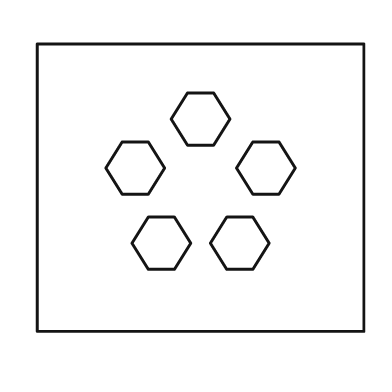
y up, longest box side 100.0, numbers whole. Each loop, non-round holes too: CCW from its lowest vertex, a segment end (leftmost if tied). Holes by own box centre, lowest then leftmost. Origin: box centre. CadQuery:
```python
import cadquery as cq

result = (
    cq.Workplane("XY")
    .moveTo(-50.0, -44.0)
    .lineTo(50.0, -44.0)
    .lineTo(50.0, 44.0)
    .lineTo(-50.0, 44.0)
    .close()
    .moveTo(-16.0, -25.0)
    .lineTo(-8.0, -25.0)
    .lineTo(-3.0, -17.0)
    .lineTo(-8.0, -9.0)
    .lineTo(-16.0, -9.0)
    .lineTo(-21.0, -17.0)
    .close()
    .moveTo(8.0, -25.0)
    .lineTo(16.0, -25.0)
    .lineTo(21.0, -17.0)
    .lineTo(16.0, -9.0)
    .lineTo(8.0, -9.0)
    .lineTo(3.0, -17.0)
    .close()
    .moveTo(-24.0, -2.0)
    .lineTo(-16.0, -2.0)
    .lineTo(-11.0, 6.0)
    .lineTo(-16.0, 14.0)
    .lineTo(-24.0, 14.0)
    .lineTo(-29.0, 6.0)
    .close()
    .moveTo(16.0, -2.0)
    .lineTo(24.0, -2.0)
    .lineTo(29.0, 6.0)
    .lineTo(24.0, 14.0)
    .lineTo(16.0, 14.0)
    .lineTo(11.0, 6.0)
    .close()
    .moveTo(-4.0, 13.0)
    .lineTo(4.0, 13.0)
    .lineTo(9.0, 21.0)
    .lineTo(4.0, 29.0)
    .lineTo(-4.0, 29.0)
    .lineTo(-9.0, 21.0)
    .close()
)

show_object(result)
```